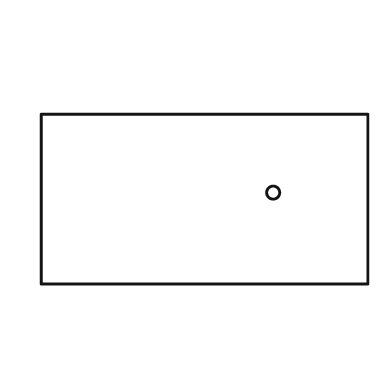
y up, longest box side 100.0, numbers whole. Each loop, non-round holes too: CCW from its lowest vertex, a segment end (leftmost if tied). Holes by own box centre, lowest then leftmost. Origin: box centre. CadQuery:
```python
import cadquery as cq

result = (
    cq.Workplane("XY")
    .moveTo(-50.0, -26.0)
    .lineTo(50.0, -26.0)
    .lineTo(50.0, 26.0)
    .lineTo(-50.0, 26.0)
    .close()
    .moveTo(21.0, 2.0)
    .circle(2.0)
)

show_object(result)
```